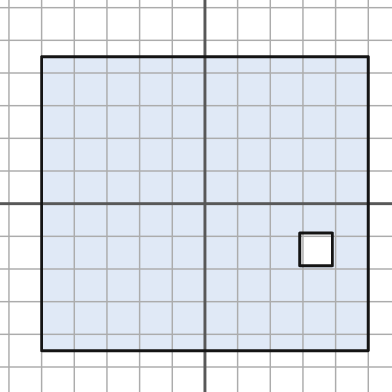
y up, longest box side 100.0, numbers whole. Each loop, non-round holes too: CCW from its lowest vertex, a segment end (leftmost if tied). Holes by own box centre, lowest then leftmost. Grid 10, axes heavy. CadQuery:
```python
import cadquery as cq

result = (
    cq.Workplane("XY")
    .moveTo(-50.0, -45.0)
    .lineTo(50.0, -45.0)
    .lineTo(50.0, 45.0)
    .lineTo(-50.0, 45.0)
    .close()
    .moveTo(29.0, -19.0)
    .lineTo(39.0, -19.0)
    .lineTo(39.0, -9.0)
    .lineTo(29.0, -9.0)
    .close()
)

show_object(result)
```